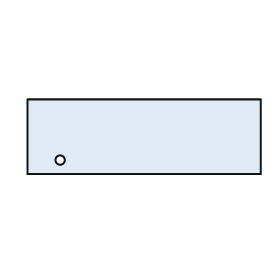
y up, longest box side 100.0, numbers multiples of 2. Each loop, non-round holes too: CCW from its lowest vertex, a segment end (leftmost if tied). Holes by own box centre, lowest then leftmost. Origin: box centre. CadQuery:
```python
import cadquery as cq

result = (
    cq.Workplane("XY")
    .moveTo(-50.0, -16.0)
    .lineTo(50.0, -16.0)
    .lineTo(50.0, 16.0)
    .lineTo(-50.0, 16.0)
    .close()
    .moveTo(-36.0, -10.0)
    .circle(2.0)
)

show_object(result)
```